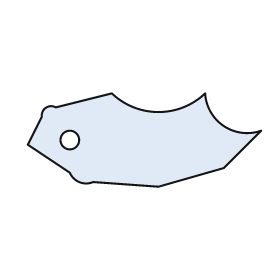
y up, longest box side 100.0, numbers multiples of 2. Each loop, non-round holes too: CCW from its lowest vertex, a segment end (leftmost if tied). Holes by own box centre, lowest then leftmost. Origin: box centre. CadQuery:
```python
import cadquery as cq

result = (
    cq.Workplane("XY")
    .moveTo(6.0, -20.0)
    .lineTo(34.0, -12.0)
    .lineTo(50.0, 4.0)
    .threePointArc((34.0, 6.0), (26.0, 20.0))
    .threePointArc((6.0, 12.0), (-14.0, 20.0))
    .lineTo(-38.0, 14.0)
    .threePointArc((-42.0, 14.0), (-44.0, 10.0))
    .lineTo(-50.0, -2.0)
    .lineTo(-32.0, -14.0)
    .threePointArc((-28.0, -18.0), (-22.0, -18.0))
    .close()
    .moveTo(-32.0, 0.0)
    .circle(4.0)
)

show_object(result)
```